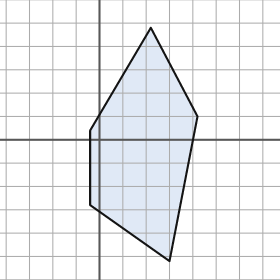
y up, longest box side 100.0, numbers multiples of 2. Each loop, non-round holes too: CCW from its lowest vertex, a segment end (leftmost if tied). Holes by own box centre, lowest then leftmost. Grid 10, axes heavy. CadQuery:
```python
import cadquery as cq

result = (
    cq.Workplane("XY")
    .moveTo(30.0, -52.0)
    .lineTo(42.0, 10.0)
    .lineTo(22.0, 48.0)
    .lineTo(-4.0, 4.0)
    .lineTo(-4.0, -28.0)
    .close()
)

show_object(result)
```